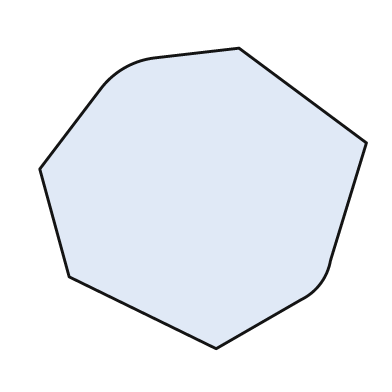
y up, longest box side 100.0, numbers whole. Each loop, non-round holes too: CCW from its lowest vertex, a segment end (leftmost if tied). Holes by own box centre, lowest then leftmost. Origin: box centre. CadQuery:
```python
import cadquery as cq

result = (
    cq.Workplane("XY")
    .moveTo(4.0, -46.0)
    .lineTo(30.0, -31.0)
    .threePointArc((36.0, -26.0), (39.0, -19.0))
    .lineTo(50.0, 17.0)
    .lineTo(11.0, 46.0)
    .lineTo(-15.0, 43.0)
    .threePointArc((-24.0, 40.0), (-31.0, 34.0))
    .lineTo(-50.0, 9.0)
    .lineTo(-41.0, -24.0)
    .close()
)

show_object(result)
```